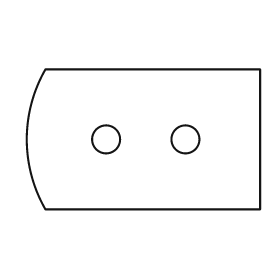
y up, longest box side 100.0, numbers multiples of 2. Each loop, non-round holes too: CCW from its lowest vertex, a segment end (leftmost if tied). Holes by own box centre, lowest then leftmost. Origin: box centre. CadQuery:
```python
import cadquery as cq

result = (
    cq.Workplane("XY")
    .moveTo(-42.0, -30.0)
    .lineTo(50.0, -30.0)
    .lineTo(50.0, 30.0)
    .lineTo(-42.0, 30.0)
    .threePointArc((-50.0, 0.0), (-42.0, -30.0))
    .close()
    .moveTo(-16.0, 0.0)
    .circle(6.0)
    .moveTo(18.0, 0.0)
    .circle(6.0)
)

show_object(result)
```